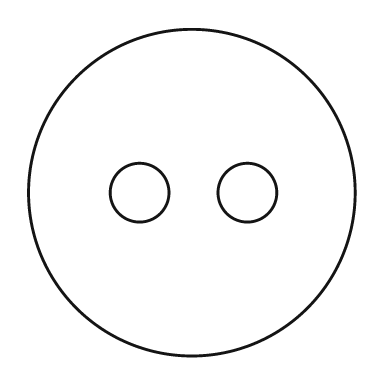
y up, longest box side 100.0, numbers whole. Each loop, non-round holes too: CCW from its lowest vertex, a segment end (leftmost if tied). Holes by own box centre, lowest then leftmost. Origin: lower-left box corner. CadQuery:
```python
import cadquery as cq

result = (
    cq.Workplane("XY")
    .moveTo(50.0, 50.0)
    .circle(50.0)
    .moveTo(34.0, 50.0)
    .circle(9.0)
    .moveTo(67.0, 50.0)
    .circle(9.0)
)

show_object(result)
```